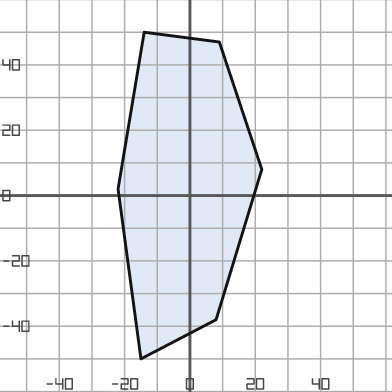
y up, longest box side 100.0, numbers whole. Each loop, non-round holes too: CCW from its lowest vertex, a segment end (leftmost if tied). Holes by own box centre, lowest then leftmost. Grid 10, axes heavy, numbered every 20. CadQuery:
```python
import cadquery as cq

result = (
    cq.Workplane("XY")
    .moveTo(-15.0, -50.0)
    .lineTo(8.0, -38.0)
    .lineTo(22.0, 8.0)
    .lineTo(9.0, 47.0)
    .lineTo(-14.0, 50.0)
    .lineTo(-22.0, 2.0)
    .close()
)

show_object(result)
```